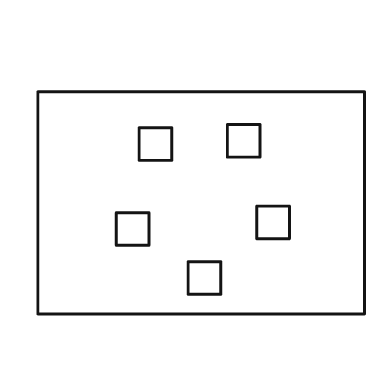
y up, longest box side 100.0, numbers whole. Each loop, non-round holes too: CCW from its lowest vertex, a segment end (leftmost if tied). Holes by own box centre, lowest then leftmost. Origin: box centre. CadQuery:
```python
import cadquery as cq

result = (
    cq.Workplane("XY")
    .moveTo(-50.0, -34.0)
    .lineTo(50.0, -34.0)
    .lineTo(50.0, 34.0)
    .lineTo(-50.0, 34.0)
    .close()
    .moveTo(-4.0, -28.0)
    .lineTo(6.0, -28.0)
    .lineTo(6.0, -18.0)
    .lineTo(-4.0, -18.0)
    .close()
    .moveTo(-26.0, -13.0)
    .lineTo(-16.0, -13.0)
    .lineTo(-16.0, -3.0)
    .lineTo(-26.0, -3.0)
    .close()
    .moveTo(17.0, -11.0)
    .lineTo(27.0, -11.0)
    .lineTo(27.0, -1.0)
    .lineTo(17.0, -1.0)
    .close()
    .moveTo(-19.0, 13.0)
    .lineTo(-9.0, 13.0)
    .lineTo(-9.0, 23.0)
    .lineTo(-19.0, 23.0)
    .close()
    .moveTo(8.0, 14.0)
    .lineTo(18.0, 14.0)
    .lineTo(18.0, 24.0)
    .lineTo(8.0, 24.0)
    .close()
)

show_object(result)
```